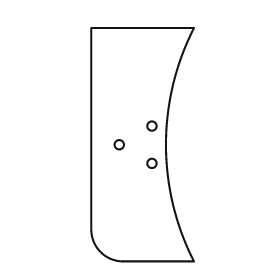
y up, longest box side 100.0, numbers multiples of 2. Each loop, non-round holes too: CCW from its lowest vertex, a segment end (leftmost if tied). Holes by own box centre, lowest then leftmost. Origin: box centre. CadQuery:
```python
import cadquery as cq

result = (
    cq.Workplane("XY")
    .moveTo(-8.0, -50.0)
    .lineTo(22.0, -50.0)
    .threePointArc((10.0, 0.0), (22.0, 50.0))
    .lineTo(-22.0, 50.0)
    .lineTo(-22.0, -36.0)
    .threePointArc((-18.0, -46.0), (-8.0, -50.0))
    .close()
    .moveTo(4.0, -8.0)
    .circle(2.0)
    .moveTo(-10.0, 0.0)
    .circle(2.0)
    .moveTo(4.0, 8.0)
    .circle(2.0)
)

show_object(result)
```